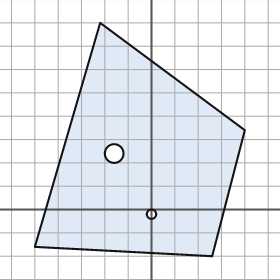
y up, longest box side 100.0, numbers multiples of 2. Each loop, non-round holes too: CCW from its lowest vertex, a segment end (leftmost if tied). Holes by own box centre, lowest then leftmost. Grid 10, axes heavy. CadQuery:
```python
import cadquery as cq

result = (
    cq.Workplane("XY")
    .moveTo(26.0, -20.0)
    .lineTo(40.0, 34.0)
    .lineTo(-22.0, 80.0)
    .lineTo(-50.0, -16.0)
    .close()
    .moveTo(0.0, -2.0)
    .circle(2.0)
    .moveTo(-16.0, 24.0)
    .circle(4.0)
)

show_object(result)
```